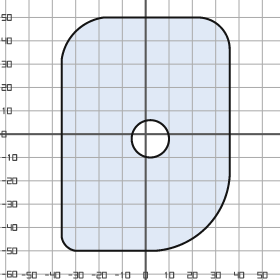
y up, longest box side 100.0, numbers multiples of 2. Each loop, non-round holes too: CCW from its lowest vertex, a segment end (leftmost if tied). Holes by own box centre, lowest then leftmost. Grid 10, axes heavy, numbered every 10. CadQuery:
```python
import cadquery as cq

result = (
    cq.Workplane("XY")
    .moveTo(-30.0, -50.0)
    .lineTo(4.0, -50.0)
    .threePointArc((26.0, -40.0), (36.0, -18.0))
    .lineTo(36.0, 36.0)
    .threePointArc((32.0, 46.0), (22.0, 50.0))
    .lineTo(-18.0, 50.0)
    .threePointArc((-30.0, 44.0), (-36.0, 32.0))
    .lineTo(-36.0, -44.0)
    .threePointArc((-34.0, -48.0), (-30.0, -50.0))
    .close()
    .moveTo(2.0, -2.0)
    .circle(8.0)
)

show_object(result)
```